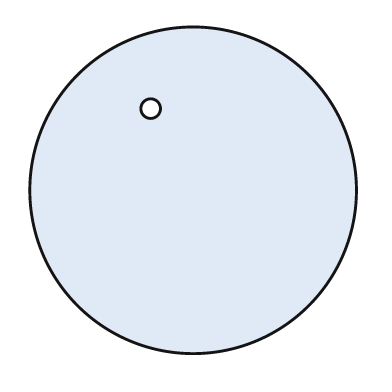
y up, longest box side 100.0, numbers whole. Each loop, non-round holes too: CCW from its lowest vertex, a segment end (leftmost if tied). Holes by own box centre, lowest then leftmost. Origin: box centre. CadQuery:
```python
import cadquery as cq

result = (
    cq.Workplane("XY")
    .moveTo(0.0, 0.0)
    .circle(50.0)
    .moveTo(-13.0, 25.0)
    .circle(3.0)
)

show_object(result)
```